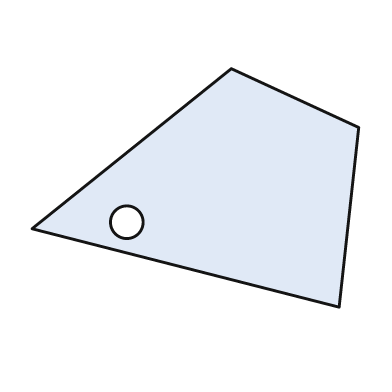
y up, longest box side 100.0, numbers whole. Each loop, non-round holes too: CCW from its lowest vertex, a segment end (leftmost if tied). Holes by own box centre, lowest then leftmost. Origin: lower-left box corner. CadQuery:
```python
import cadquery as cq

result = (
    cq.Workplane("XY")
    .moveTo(94.0, 0.0)
    .lineTo(100.0, 55.0)
    .lineTo(61.0, 73.0)
    .lineTo(0.0, 24.0)
    .close()
    .moveTo(29.0, 26.0)
    .circle(5.0)
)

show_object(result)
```